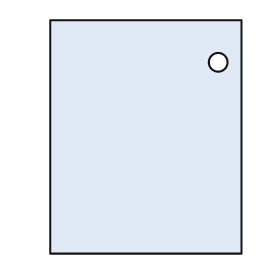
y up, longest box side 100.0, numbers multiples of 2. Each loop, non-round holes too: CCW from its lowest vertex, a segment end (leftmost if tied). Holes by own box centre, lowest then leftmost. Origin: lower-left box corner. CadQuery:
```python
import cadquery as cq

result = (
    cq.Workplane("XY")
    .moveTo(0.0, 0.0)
    .lineTo(82.0, 0.0)
    .lineTo(82.0, 100.0)
    .lineTo(0.0, 100.0)
    .close()
    .moveTo(72.0, 82.0)
    .circle(4.0)
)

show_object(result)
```